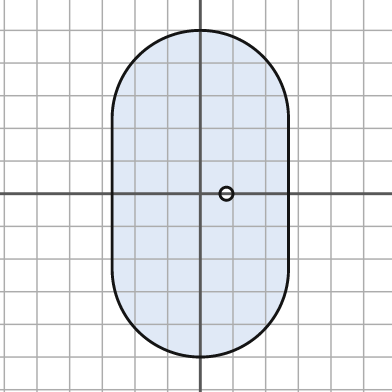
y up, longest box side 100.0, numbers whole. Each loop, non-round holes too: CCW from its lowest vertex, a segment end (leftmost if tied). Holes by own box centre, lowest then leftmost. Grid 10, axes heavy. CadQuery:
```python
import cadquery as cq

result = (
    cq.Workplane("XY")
    .moveTo(-27.0, -23.0)
    .threePointArc((0.0, -50.0), (27.0, -23.0))
    .lineTo(27.0, 23.0)
    .threePointArc((0.0, 50.0), (-27.0, 23.0))
    .close()
    .moveTo(8.0, 0.0)
    .circle(2.0)
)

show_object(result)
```